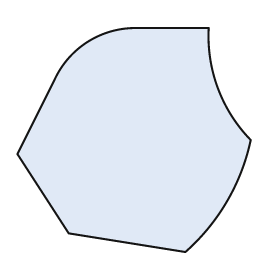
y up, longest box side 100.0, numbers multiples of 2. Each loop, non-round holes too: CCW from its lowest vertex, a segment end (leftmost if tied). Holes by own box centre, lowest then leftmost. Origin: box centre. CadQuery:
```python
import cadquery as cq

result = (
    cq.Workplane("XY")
    .moveTo(22.0, -48.0)
    .threePointArc((40.0, -26.0), (50.0, 0.0))
    .threePointArc((36.0, 22.0), (32.0, 48.0))
    .lineTo(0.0, 48.0)
    .threePointArc((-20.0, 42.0), (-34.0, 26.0))
    .lineTo(-50.0, -6.0)
    .lineTo(-28.0, -40.0)
    .close()
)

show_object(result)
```